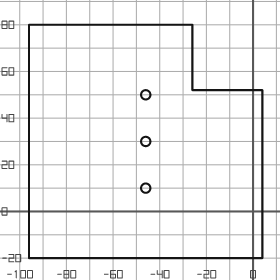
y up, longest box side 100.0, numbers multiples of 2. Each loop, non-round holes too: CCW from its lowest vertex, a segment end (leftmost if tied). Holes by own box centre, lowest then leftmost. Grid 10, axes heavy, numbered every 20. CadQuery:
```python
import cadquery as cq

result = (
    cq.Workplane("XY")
    .moveTo(-96.0, -20.0)
    .lineTo(4.0, -20.0)
    .lineTo(4.0, 52.0)
    .lineTo(-26.0, 52.0)
    .lineTo(-26.0, 80.0)
    .lineTo(-96.0, 80.0)
    .close()
    .moveTo(-46.0, 10.0)
    .circle(2.0)
    .moveTo(-46.0, 30.0)
    .circle(2.0)
    .moveTo(-46.0, 50.0)
    .circle(2.0)
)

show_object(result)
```